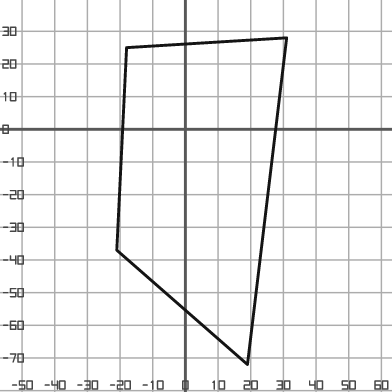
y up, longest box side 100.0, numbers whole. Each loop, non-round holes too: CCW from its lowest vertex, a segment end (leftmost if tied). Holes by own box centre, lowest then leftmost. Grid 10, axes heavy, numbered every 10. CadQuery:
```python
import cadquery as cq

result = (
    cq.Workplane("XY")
    .moveTo(19.0, -72.0)
    .lineTo(31.0, 28.0)
    .lineTo(-18.0, 25.0)
    .lineTo(-21.0, -37.0)
    .close()
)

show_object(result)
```